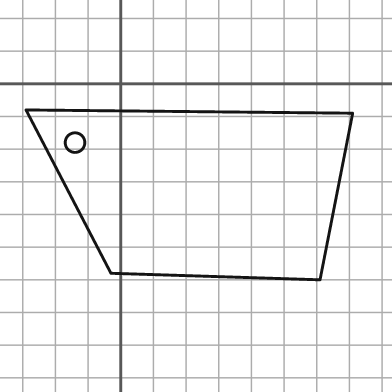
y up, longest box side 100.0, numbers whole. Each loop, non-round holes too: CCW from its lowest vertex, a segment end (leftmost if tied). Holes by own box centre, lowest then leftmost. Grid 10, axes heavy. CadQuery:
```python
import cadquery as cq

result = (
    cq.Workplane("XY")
    .moveTo(61.0, -60.0)
    .lineTo(71.0, -9.0)
    .lineTo(-29.0, -8.0)
    .lineTo(-3.0, -58.0)
    .close()
    .moveTo(-14.0, -18.0)
    .circle(3.0)
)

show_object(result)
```